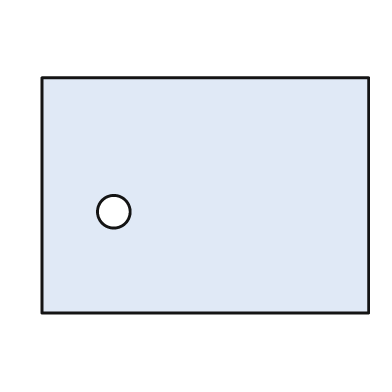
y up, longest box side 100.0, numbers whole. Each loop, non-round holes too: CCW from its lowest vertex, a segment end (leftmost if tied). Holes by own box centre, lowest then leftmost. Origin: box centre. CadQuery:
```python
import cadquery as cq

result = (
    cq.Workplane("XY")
    .moveTo(-50.0, -36.0)
    .lineTo(50.0, -36.0)
    .lineTo(50.0, 36.0)
    .lineTo(-50.0, 36.0)
    .close()
    .moveTo(-28.0, -5.0)
    .circle(5.0)
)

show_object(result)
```